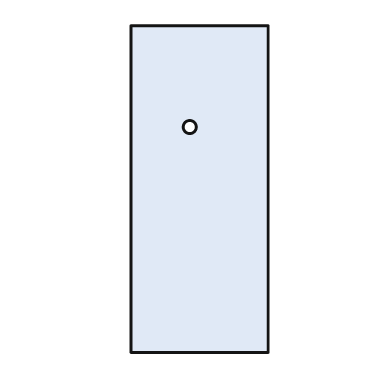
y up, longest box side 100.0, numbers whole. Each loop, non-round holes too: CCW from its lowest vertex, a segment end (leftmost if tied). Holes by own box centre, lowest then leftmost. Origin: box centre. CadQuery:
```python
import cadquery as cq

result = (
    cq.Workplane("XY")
    .moveTo(-21.0, -50.0)
    .lineTo(21.0, -50.0)
    .lineTo(21.0, 50.0)
    .lineTo(-21.0, 50.0)
    .close()
    .moveTo(-3.0, 19.0)
    .circle(2.0)
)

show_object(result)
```